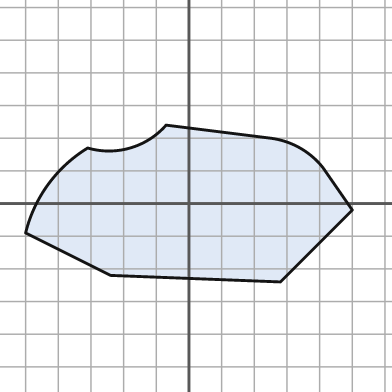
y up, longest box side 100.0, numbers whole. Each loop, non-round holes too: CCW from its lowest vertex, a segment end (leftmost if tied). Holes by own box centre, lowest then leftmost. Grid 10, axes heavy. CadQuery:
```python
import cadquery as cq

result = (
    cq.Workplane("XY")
    .moveTo(28.0, -24.0)
    .lineTo(50.0, -2.0)
    .lineTo(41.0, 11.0)
    .threePointArc((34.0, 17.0), (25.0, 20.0))
    .lineTo(-7.0, 24.0)
    .threePointArc((-18.0, 17.0), (-31.0, 17.0))
    .threePointArc((-43.0, 6.0), (-50.0, -9.0))
    .lineTo(-24.0, -22.0)
    .close()
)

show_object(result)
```